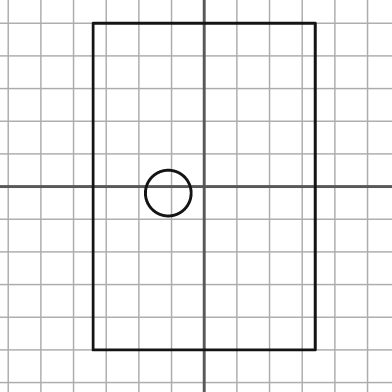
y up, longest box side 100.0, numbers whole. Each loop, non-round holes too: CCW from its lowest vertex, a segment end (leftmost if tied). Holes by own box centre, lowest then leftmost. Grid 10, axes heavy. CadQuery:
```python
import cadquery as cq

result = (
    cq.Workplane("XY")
    .moveTo(-34.0, -50.0)
    .lineTo(34.0, -50.0)
    .lineTo(34.0, 50.0)
    .lineTo(-34.0, 50.0)
    .close()
    .moveTo(-11.0, -2.0)
    .circle(7.0)
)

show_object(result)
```